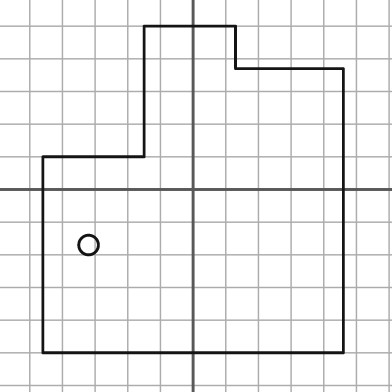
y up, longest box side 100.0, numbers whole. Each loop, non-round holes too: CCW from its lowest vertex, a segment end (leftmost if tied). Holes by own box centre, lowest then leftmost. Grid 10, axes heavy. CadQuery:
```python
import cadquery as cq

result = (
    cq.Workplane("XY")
    .moveTo(-46.0, -50.0)
    .lineTo(46.0, -50.0)
    .lineTo(46.0, 37.0)
    .lineTo(13.0, 37.0)
    .lineTo(13.0, 50.0)
    .lineTo(-15.0, 50.0)
    .lineTo(-15.0, 10.0)
    .lineTo(-46.0, 10.0)
    .close()
    .moveTo(-32.0, -17.0)
    .circle(3.0)
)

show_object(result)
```